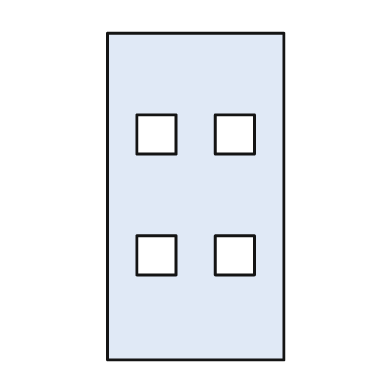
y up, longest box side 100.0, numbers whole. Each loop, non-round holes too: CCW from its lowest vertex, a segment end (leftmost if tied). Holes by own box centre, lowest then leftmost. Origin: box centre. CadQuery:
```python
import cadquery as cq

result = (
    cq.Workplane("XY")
    .moveTo(-27.0, -50.0)
    .lineTo(27.0, -50.0)
    .lineTo(27.0, 50.0)
    .lineTo(-27.0, 50.0)
    .close()
    .moveTo(-18.0, -24.0)
    .lineTo(-6.0, -24.0)
    .lineTo(-6.0, -12.0)
    .lineTo(-18.0, -12.0)
    .close()
    .moveTo(6.0, -24.0)
    .lineTo(18.0, -24.0)
    .lineTo(18.0, -12.0)
    .lineTo(6.0, -12.0)
    .close()
    .moveTo(-18.0, 13.0)
    .lineTo(-6.0, 13.0)
    .lineTo(-6.0, 25.0)
    .lineTo(-18.0, 25.0)
    .close()
    .moveTo(6.0, 13.0)
    .lineTo(18.0, 13.0)
    .lineTo(18.0, 25.0)
    .lineTo(6.0, 25.0)
    .close()
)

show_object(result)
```